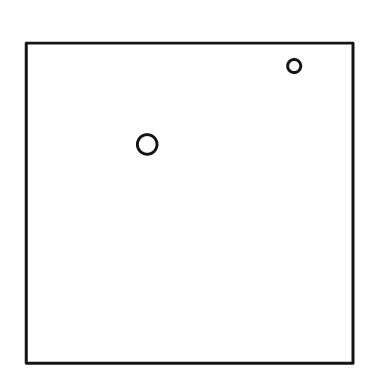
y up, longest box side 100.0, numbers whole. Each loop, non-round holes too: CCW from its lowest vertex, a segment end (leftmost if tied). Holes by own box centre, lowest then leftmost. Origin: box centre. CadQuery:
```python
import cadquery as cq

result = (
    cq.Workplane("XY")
    .moveTo(-50.0, -49.0)
    .lineTo(50.0, -49.0)
    .lineTo(50.0, 49.0)
    .lineTo(-50.0, 49.0)
    .close()
    .moveTo(-13.0, 18.0)
    .circle(3.0)
    .moveTo(32.0, 42.0)
    .circle(2.0)
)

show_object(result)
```